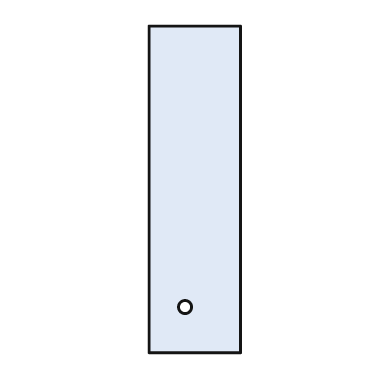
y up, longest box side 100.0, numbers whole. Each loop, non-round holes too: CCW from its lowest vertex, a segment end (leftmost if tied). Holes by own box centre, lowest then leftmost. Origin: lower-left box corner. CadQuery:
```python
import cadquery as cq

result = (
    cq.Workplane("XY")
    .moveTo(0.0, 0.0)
    .lineTo(28.0, 0.0)
    .lineTo(28.0, 100.0)
    .lineTo(0.0, 100.0)
    .close()
    .moveTo(11.0, 14.0)
    .circle(2.0)
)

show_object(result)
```